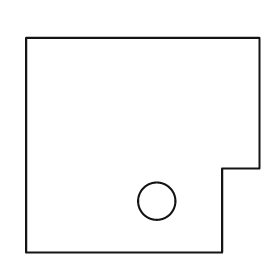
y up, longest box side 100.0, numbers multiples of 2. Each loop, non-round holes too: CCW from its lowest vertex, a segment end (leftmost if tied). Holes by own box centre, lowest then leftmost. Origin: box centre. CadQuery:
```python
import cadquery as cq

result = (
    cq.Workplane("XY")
    .moveTo(-50.0, -46.0)
    .lineTo(34.0, -46.0)
    .lineTo(34.0, -10.0)
    .lineTo(50.0, -10.0)
    .lineTo(50.0, 46.0)
    .lineTo(-50.0, 46.0)
    .close()
    .moveTo(6.0, -24.0)
    .circle(8.0)
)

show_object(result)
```